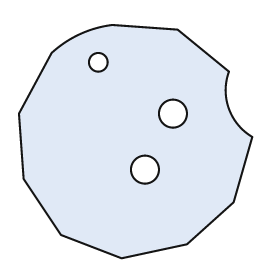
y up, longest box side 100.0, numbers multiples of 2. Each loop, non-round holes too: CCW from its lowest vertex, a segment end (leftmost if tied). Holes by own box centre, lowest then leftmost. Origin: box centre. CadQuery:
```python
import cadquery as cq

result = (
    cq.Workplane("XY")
    .moveTo(-6.0, -50.0)
    .lineTo(22.0, -44.0)
    .lineTo(42.0, -26.0)
    .lineTo(50.0, 2.0)
    .threePointArc((40.0, 14.0), (40.0, 30.0))
    .lineTo(18.0, 48.0)
    .lineTo(-10.0, 50.0)
    .threePointArc((-24.0, 46.0), (-36.0, 38.0))
    .lineTo(-50.0, 12.0)
    .lineTo(-48.0, -16.0)
    .lineTo(-32.0, -40.0)
    .close()
    .moveTo(4.0, -12.0)
    .circle(6.0)
    .moveTo(16.0, 12.0)
    .circle(6.0)
    .moveTo(-16.0, 34.0)
    .circle(4.0)
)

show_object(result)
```